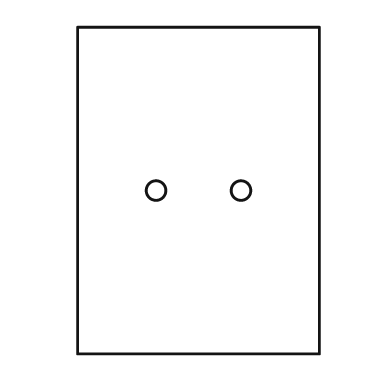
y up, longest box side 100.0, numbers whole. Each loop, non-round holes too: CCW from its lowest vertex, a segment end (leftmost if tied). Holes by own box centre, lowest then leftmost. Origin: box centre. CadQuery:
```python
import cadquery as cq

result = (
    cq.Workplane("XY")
    .moveTo(-37.0, -50.0)
    .lineTo(37.0, -50.0)
    .lineTo(37.0, 50.0)
    .lineTo(-37.0, 50.0)
    .close()
    .moveTo(-13.0, 0.0)
    .circle(3.0)
    .moveTo(13.0, 0.0)
    .circle(3.0)
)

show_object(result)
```